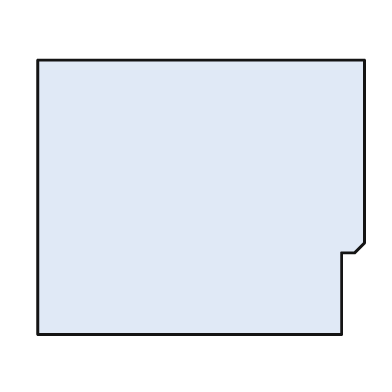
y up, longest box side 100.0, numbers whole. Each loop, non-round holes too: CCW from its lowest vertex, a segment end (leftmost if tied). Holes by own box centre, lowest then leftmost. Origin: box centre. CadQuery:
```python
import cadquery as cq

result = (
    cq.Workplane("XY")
    .moveTo(-50.0, -42.0)
    .lineTo(43.0, -42.0)
    .lineTo(43.0, -17.0)
    .lineTo(47.0, -17.0)
    .lineTo(50.0, -14.0)
    .lineTo(50.0, 42.0)
    .lineTo(-50.0, 42.0)
    .close()
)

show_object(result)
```